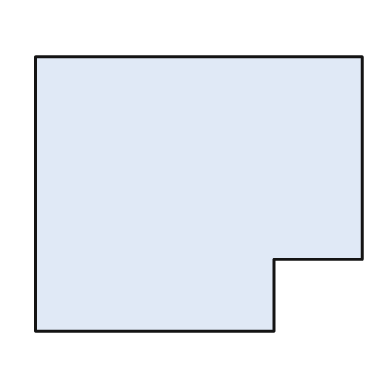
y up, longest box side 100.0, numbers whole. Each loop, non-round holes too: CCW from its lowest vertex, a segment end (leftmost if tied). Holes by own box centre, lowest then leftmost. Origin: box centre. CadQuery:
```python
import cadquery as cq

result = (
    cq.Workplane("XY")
    .moveTo(-50.0, -42.0)
    .lineTo(23.0, -42.0)
    .lineTo(23.0, -20.0)
    .lineTo(50.0, -20.0)
    .lineTo(50.0, 42.0)
    .lineTo(-50.0, 42.0)
    .close()
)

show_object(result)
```